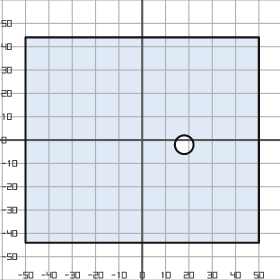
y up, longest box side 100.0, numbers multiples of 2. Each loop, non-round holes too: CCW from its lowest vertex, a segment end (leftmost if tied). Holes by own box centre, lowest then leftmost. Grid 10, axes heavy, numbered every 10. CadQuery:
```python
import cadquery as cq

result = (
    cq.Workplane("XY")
    .moveTo(-50.0, -44.0)
    .lineTo(50.0, -44.0)
    .lineTo(50.0, 44.0)
    .lineTo(-50.0, 44.0)
    .close()
    .moveTo(18.0, -2.0)
    .circle(4.0)
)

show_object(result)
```